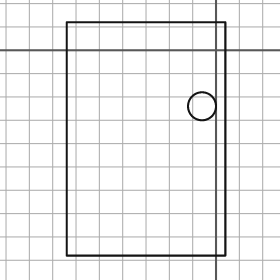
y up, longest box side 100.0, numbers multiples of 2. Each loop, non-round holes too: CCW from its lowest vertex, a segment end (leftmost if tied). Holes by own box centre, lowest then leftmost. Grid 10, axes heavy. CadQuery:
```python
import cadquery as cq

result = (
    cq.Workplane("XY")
    .moveTo(-64.0, -88.0)
    .lineTo(4.0, -88.0)
    .lineTo(4.0, 12.0)
    .lineTo(-64.0, 12.0)
    .close()
    .moveTo(-6.0, -24.0)
    .circle(6.0)
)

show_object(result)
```